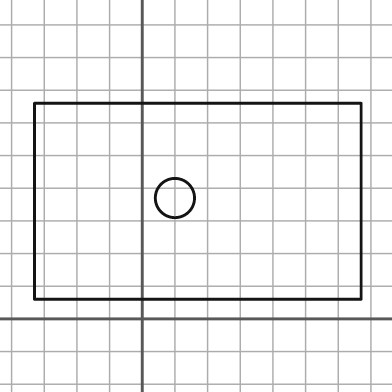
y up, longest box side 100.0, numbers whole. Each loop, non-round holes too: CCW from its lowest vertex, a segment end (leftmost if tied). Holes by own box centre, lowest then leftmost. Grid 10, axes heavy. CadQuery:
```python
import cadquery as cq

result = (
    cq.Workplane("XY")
    .moveTo(-33.0, 6.0)
    .lineTo(67.0, 6.0)
    .lineTo(67.0, 66.0)
    .lineTo(-33.0, 66.0)
    .close()
    .moveTo(10.0, 37.0)
    .circle(6.0)
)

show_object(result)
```